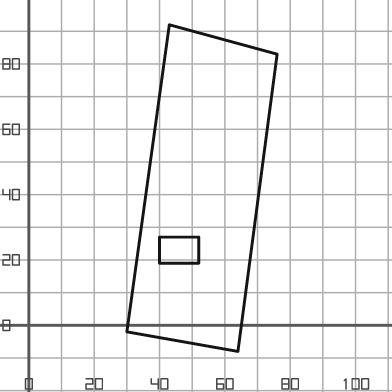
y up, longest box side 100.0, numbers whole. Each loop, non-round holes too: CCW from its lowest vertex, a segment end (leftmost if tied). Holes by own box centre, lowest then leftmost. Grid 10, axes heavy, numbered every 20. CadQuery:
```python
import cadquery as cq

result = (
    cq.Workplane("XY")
    .moveTo(64.0, -8.0)
    .lineTo(76.0, 83.0)
    .lineTo(43.0, 92.0)
    .lineTo(30.0, -2.0)
    .close()
    .moveTo(40.0, 19.0)
    .lineTo(52.0, 19.0)
    .lineTo(52.0, 27.0)
    .lineTo(40.0, 27.0)
    .close()
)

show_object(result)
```